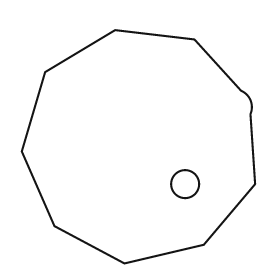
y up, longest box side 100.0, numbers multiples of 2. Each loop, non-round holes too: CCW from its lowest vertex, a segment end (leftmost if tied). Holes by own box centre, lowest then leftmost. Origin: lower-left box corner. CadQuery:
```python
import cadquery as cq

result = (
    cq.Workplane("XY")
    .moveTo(44.0, 0.0)
    .lineTo(78.0, 8.0)
    .lineTo(100.0, 34.0)
    .lineTo(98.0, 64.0)
    .threePointArc((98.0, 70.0), (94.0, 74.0))
    .lineTo(74.0, 96.0)
    .lineTo(40.0, 100.0)
    .lineTo(10.0, 82.0)
    .lineTo(0.0, 48.0)
    .lineTo(14.0, 16.0)
    .close()
    .moveTo(70.0, 34.0)
    .circle(6.0)
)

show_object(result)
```